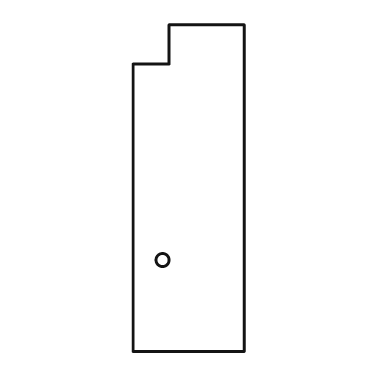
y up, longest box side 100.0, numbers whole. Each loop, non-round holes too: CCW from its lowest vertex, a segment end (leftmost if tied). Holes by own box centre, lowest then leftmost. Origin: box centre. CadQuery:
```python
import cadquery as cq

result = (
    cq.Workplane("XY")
    .moveTo(-17.0, -50.0)
    .lineTo(17.0, -50.0)
    .lineTo(17.0, 50.0)
    .lineTo(-6.0, 50.0)
    .lineTo(-6.0, 38.0)
    .lineTo(-17.0, 38.0)
    .close()
    .moveTo(-8.0, -22.0)
    .circle(2.0)
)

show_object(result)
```